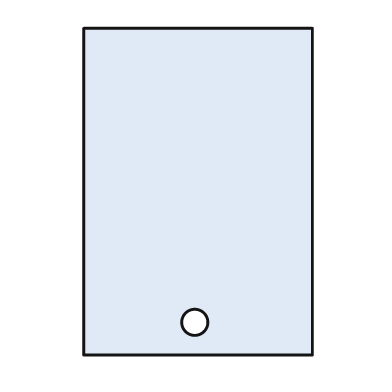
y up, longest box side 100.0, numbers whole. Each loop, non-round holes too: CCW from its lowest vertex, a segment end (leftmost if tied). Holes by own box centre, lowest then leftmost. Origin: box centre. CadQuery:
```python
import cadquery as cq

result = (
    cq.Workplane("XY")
    .moveTo(-35.0, -50.0)
    .lineTo(35.0, -50.0)
    .lineTo(35.0, 50.0)
    .lineTo(-35.0, 50.0)
    .close()
    .moveTo(-1.0, -40.0)
    .circle(4.0)
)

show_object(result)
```